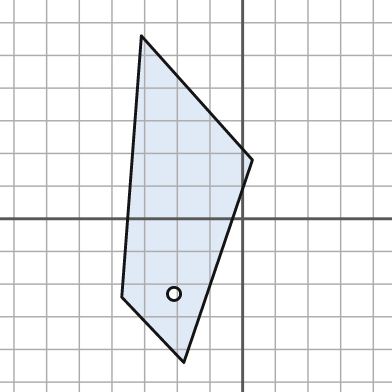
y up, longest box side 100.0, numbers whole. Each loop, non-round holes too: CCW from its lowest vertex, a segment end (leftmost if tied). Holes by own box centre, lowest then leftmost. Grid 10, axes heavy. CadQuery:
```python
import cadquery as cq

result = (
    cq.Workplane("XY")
    .moveTo(-18.0, -44.0)
    .lineTo(3.0, 18.0)
    .lineTo(-31.0, 56.0)
    .lineTo(-37.0, -24.0)
    .close()
    .moveTo(-21.0, -23.0)
    .circle(2.0)
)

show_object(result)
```